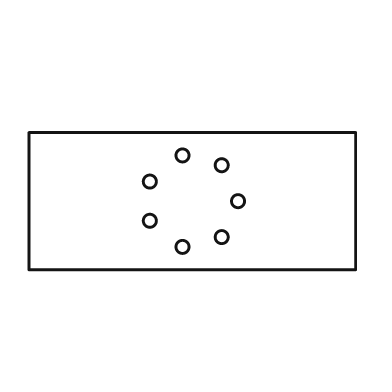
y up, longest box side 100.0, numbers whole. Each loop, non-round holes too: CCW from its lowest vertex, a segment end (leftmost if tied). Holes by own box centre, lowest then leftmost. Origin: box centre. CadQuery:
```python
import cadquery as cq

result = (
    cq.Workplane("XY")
    .moveTo(-50.0, -21.0)
    .lineTo(50.0, -21.0)
    .lineTo(50.0, 21.0)
    .lineTo(-50.0, 21.0)
    .close()
    .moveTo(-3.0, -14.0)
    .circle(2.0)
    .moveTo(9.0, -11.0)
    .circle(2.0)
    .moveTo(-13.0, -6.0)
    .circle(2.0)
    .moveTo(14.0, 0.0)
    .circle(2.0)
    .moveTo(-13.0, 6.0)
    .circle(2.0)
    .moveTo(9.0, 11.0)
    .circle(2.0)
    .moveTo(-3.0, 14.0)
    .circle(2.0)
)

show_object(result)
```